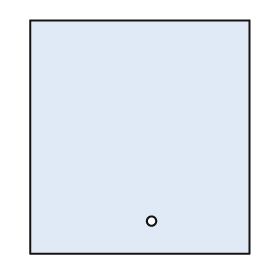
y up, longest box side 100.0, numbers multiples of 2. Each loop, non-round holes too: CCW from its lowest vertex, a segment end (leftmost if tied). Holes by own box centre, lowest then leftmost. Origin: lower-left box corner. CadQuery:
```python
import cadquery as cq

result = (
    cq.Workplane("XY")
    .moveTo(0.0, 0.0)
    .lineTo(94.0, 0.0)
    .lineTo(94.0, 100.0)
    .lineTo(0.0, 100.0)
    .close()
    .moveTo(52.0, 14.0)
    .circle(2.0)
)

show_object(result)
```